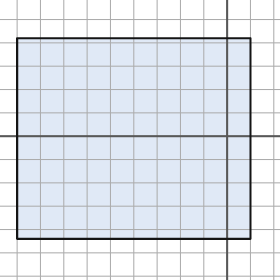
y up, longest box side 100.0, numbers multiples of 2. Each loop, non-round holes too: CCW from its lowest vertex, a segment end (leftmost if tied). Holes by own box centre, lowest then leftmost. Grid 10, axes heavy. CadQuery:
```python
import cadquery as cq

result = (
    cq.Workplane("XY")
    .moveTo(-90.0, -44.0)
    .lineTo(10.0, -44.0)
    .lineTo(10.0, 42.0)
    .lineTo(-90.0, 42.0)
    .close()
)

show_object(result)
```